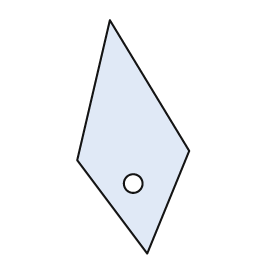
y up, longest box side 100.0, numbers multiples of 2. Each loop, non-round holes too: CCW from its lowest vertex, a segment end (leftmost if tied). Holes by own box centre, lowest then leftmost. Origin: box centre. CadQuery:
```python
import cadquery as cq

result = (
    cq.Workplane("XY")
    .moveTo(6.0, -50.0)
    .lineTo(24.0, -6.0)
    .lineTo(-10.0, 50.0)
    .lineTo(-24.0, -10.0)
    .close()
    .moveTo(0.0, -20.0)
    .circle(4.0)
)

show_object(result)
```